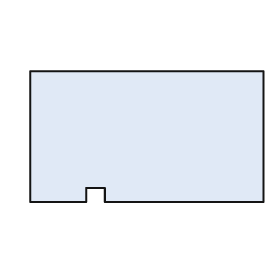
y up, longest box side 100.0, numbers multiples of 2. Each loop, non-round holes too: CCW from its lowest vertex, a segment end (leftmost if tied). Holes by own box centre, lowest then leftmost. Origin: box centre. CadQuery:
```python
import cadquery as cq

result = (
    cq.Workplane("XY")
    .moveTo(-50.0, -28.0)
    .lineTo(-26.0, -28.0)
    .lineTo(-26.0, -22.0)
    .lineTo(-18.0, -22.0)
    .lineTo(-18.0, -28.0)
    .lineTo(50.0, -28.0)
    .lineTo(50.0, 28.0)
    .lineTo(-50.0, 28.0)
    .close()
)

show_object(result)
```